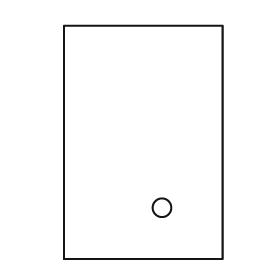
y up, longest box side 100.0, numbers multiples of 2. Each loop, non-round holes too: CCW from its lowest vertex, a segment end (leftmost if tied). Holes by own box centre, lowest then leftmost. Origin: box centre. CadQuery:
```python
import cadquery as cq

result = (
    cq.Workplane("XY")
    .moveTo(-34.0, -50.0)
    .lineTo(34.0, -50.0)
    .lineTo(34.0, 50.0)
    .lineTo(-34.0, 50.0)
    .close()
    .moveTo(8.0, -28.0)
    .circle(4.0)
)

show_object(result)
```